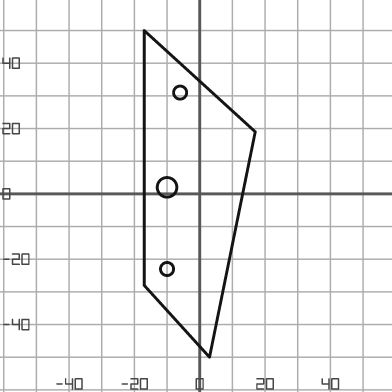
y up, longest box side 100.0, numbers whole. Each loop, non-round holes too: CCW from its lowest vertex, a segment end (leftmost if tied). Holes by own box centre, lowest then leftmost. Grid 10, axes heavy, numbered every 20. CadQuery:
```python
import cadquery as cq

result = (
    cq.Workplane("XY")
    .moveTo(3.0, -50.0)
    .lineTo(17.0, 19.0)
    .lineTo(-17.0, 50.0)
    .lineTo(-17.0, -28.0)
    .close()
    .moveTo(-10.0, -23.0)
    .circle(2.0)
    .moveTo(-10.0, 2.0)
    .circle(3.0)
    .moveTo(-6.0, 31.0)
    .circle(2.0)
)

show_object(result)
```